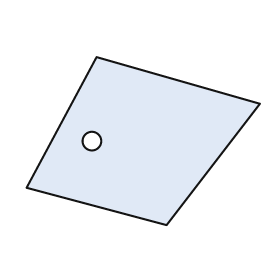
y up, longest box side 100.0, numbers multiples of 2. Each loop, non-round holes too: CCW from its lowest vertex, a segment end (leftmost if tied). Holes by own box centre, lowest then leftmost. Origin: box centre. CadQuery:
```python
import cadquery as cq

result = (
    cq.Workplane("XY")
    .moveTo(10.0, -36.0)
    .lineTo(50.0, 16.0)
    .lineTo(-20.0, 36.0)
    .lineTo(-50.0, -20.0)
    .close()
    .moveTo(-22.0, 0.0)
    .circle(4.0)
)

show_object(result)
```